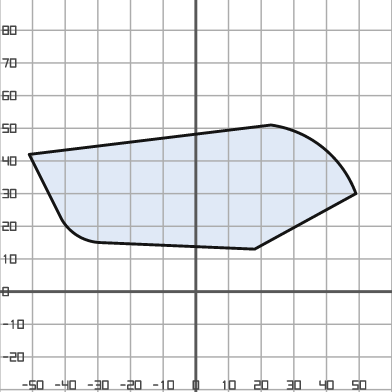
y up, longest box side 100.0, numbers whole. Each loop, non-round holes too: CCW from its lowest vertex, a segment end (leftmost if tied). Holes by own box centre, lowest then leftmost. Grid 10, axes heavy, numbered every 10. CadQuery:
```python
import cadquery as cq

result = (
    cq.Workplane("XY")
    .moveTo(18.0, 13.0)
    .lineTo(49.0, 30.0)
    .threePointArc((39.0, 44.0), (23.0, 51.0))
    .lineTo(-51.0, 42.0)
    .lineTo(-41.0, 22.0)
    .threePointArc((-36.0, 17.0), (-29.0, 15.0))
    .close()
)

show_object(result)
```